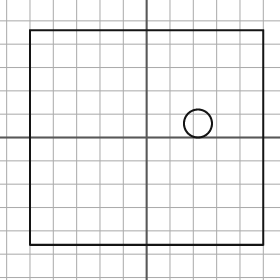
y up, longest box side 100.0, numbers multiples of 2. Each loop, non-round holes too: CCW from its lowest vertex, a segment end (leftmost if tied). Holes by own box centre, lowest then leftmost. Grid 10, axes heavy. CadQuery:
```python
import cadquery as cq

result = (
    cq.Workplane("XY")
    .moveTo(-50.0, -46.0)
    .lineTo(50.0, -46.0)
    .lineTo(50.0, 46.0)
    .lineTo(-50.0, 46.0)
    .close()
    .moveTo(22.0, 6.0)
    .circle(6.0)
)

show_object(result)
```